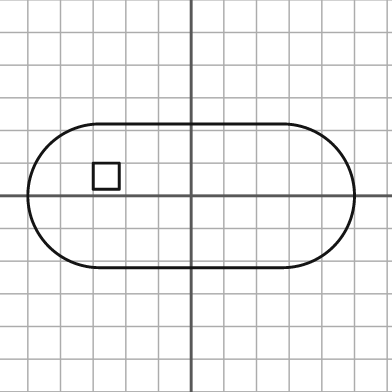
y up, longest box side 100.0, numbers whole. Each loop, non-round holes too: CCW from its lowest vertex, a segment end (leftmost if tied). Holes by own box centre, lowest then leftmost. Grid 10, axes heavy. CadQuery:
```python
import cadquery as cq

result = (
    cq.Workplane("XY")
    .moveTo(-28.0, -22.0)
    .lineTo(28.0, -22.0)
    .threePointArc((50.0, 0.0), (28.0, 22.0))
    .lineTo(-28.0, 22.0)
    .threePointArc((-50.0, 0.0), (-28.0, -22.0))
    .close()
    .moveTo(-30.0, 2.0)
    .lineTo(-22.0, 2.0)
    .lineTo(-22.0, 10.0)
    .lineTo(-30.0, 10.0)
    .close()
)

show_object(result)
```